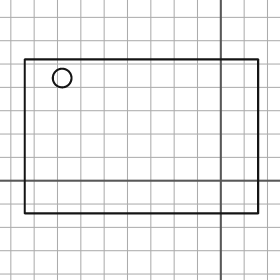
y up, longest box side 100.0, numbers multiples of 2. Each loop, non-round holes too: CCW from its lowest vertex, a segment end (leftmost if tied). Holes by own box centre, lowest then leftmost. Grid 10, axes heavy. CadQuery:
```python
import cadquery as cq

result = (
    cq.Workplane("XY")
    .moveTo(-84.0, -14.0)
    .lineTo(16.0, -14.0)
    .lineTo(16.0, 52.0)
    .lineTo(-84.0, 52.0)
    .close()
    .moveTo(-68.0, 44.0)
    .circle(4.0)
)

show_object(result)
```